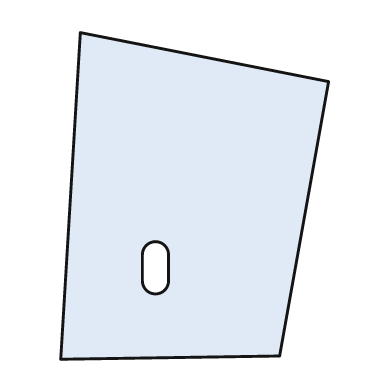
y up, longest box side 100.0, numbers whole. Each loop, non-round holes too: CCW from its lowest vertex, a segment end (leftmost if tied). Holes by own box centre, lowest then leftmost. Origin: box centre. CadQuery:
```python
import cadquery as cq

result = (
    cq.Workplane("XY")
    .moveTo(-41.0, -50.0)
    .lineTo(26.0, -49.0)
    .lineTo(41.0, 35.0)
    .lineTo(-35.0, 50.0)
    .close()
    .moveTo(-16.0, -26.0)
    .threePointArc((-12.0, -30.0), (-8.0, -26.0))
    .lineTo(-8.0, -18.0)
    .threePointArc((-12.0, -14.0), (-16.0, -18.0))
    .close()
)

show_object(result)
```